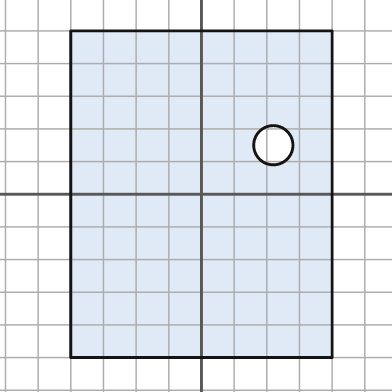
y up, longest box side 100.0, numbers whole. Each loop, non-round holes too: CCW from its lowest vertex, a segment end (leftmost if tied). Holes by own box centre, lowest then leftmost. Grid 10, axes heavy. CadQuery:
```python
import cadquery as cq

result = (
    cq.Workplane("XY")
    .moveTo(-40.0, -50.0)
    .lineTo(40.0, -50.0)
    .lineTo(40.0, 50.0)
    .lineTo(-40.0, 50.0)
    .close()
    .moveTo(22.0, 15.0)
    .circle(6.0)
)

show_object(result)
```